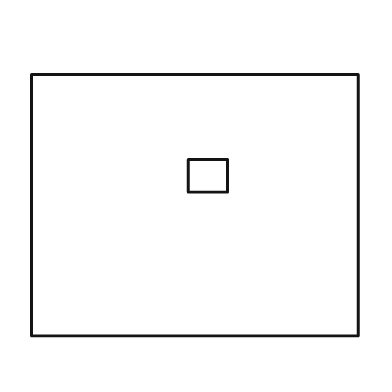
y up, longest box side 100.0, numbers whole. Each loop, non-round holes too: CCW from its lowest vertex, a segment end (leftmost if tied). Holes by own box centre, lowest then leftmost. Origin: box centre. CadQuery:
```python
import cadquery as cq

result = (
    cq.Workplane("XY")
    .moveTo(-50.0, -40.0)
    .lineTo(50.0, -40.0)
    .lineTo(50.0, 40.0)
    .lineTo(-50.0, 40.0)
    .close()
    .moveTo(-2.0, 4.0)
    .lineTo(10.0, 4.0)
    .lineTo(10.0, 14.0)
    .lineTo(-2.0, 14.0)
    .close()
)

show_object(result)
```